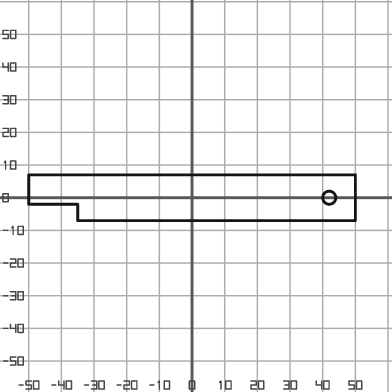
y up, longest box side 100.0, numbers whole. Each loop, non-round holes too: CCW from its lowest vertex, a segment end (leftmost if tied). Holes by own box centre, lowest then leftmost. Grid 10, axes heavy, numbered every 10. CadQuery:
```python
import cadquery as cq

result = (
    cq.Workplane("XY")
    .moveTo(-35.0, -7.0)
    .lineTo(50.0, -7.0)
    .lineTo(50.0, 7.0)
    .lineTo(-50.0, 7.0)
    .lineTo(-50.0, -2.0)
    .lineTo(-35.0, -2.0)
    .close()
    .moveTo(42.0, 0.0)
    .circle(2.0)
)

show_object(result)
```